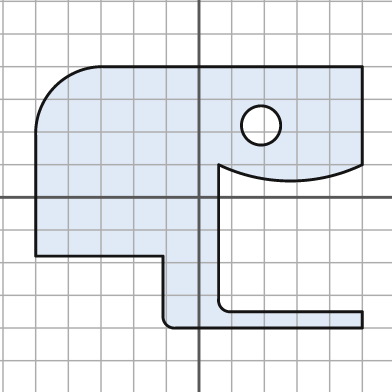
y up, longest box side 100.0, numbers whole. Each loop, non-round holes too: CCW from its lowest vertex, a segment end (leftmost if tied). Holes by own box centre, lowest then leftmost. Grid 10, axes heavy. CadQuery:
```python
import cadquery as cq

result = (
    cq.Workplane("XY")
    .moveTo(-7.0, -40.0)
    .lineTo(50.0, -40.0)
    .lineTo(50.0, -35.0)
    .lineTo(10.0, -35.0)
    .threePointArc((7.0, -34.0), (6.0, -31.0))
    .lineTo(6.0, 10.0)
    .threePointArc((28.0, 5.0), (50.0, 10.0))
    .lineTo(50.0, 40.0)
    .lineTo(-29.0, 40.0)
    .threePointArc((-44.0, 34.0), (-50.0, 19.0))
    .lineTo(-50.0, -18.0)
    .lineTo(-11.0, -18.0)
    .lineTo(-11.0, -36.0)
    .threePointArc((-10.0, -39.0), (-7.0, -40.0))
    .close()
    .moveTo(19.0, 22.0)
    .circle(6.0)
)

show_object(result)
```